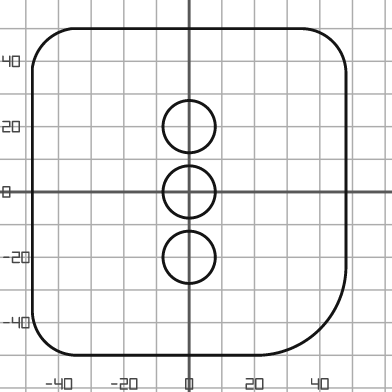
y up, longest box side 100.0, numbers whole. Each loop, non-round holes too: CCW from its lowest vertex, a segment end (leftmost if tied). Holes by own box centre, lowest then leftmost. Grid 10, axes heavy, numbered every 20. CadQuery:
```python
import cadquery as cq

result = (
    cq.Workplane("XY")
    .moveTo(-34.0, -50.0)
    .lineTo(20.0, -50.0)
    .threePointArc((40.0, -42.0), (48.0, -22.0))
    .lineTo(48.0, 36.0)
    .threePointArc((44.0, 46.0), (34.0, 50.0))
    .lineTo(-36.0, 50.0)
    .threePointArc((-44.0, 46.0), (-48.0, 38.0))
    .lineTo(-48.0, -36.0)
    .threePointArc((-44.0, -46.0), (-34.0, -50.0))
    .close()
    .moveTo(0.0, -20.0)
    .circle(8.0)
    .moveTo(0.0, 0.0)
    .circle(8.0)
    .moveTo(0.0, 20.0)
    .circle(8.0)
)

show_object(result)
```